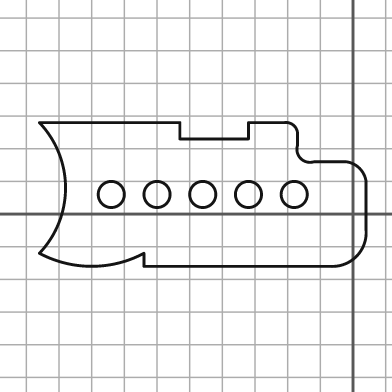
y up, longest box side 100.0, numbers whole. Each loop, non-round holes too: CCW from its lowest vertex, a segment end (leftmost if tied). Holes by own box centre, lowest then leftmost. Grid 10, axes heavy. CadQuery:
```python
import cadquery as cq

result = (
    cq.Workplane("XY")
    .moveTo(-64.0, -16.0)
    .lineTo(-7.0, -16.0)
    .threePointArc((1.0, -13.0), (4.0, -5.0))
    .lineTo(4.0, 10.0)
    .threePointArc((2.0, 14.0), (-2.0, 16.0))
    .lineTo(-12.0, 16.0)
    .threePointArc((-16.0, 17.0), (-17.0, 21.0))
    .lineTo(-17.0, 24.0)
    .threePointArc((-18.0, 27.0), (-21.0, 28.0))
    .lineTo(-32.0, 28.0)
    .lineTo(-32.0, 23.0)
    .lineTo(-53.0, 23.0)
    .lineTo(-53.0, 28.0)
    .lineTo(-96.0, 28.0)
    .threePointArc((-88.0, 8.0), (-96.0, -12.0))
    .threePointArc((-80.0, -16.0), (-64.0, -12.0))
    .close()
    .moveTo(-74.0, 6.0)
    .circle(4.0)
    .moveTo(-60.0, 6.0)
    .circle(4.0)
    .moveTo(-46.0, 6.0)
    .circle(4.0)
    .moveTo(-32.0, 6.0)
    .circle(4.0)
    .moveTo(-18.0, 6.0)
    .circle(4.0)
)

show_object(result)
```